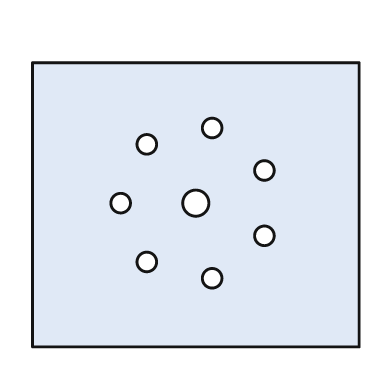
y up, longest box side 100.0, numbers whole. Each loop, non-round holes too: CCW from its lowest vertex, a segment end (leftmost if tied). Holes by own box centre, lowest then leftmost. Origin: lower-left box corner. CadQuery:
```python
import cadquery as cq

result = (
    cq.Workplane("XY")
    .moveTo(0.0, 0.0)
    .lineTo(100.0, 0.0)
    .lineTo(100.0, 87.0)
    .lineTo(0.0, 87.0)
    .close()
    .moveTo(55.0, 21.0)
    .circle(3.0)
    .moveTo(35.0, 26.0)
    .circle(3.0)
    .moveTo(71.0, 34.0)
    .circle(3.0)
    .moveTo(27.0, 44.0)
    .circle(3.0)
    .moveTo(50.0, 44.0)
    .circle(4.0)
    .moveTo(71.0, 54.0)
    .circle(3.0)
    .moveTo(35.0, 62.0)
    .circle(3.0)
    .moveTo(55.0, 67.0)
    .circle(3.0)
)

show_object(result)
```